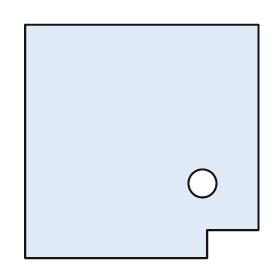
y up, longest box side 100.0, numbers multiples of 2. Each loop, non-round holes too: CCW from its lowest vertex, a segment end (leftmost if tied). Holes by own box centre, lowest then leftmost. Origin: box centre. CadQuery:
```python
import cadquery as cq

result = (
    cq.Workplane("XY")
    .moveTo(-50.0, -50.0)
    .lineTo(28.0, -50.0)
    .lineTo(28.0, -38.0)
    .lineTo(50.0, -38.0)
    .lineTo(50.0, 50.0)
    .lineTo(-50.0, 50.0)
    .close()
    .moveTo(26.0, -18.0)
    .circle(6.0)
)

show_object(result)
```